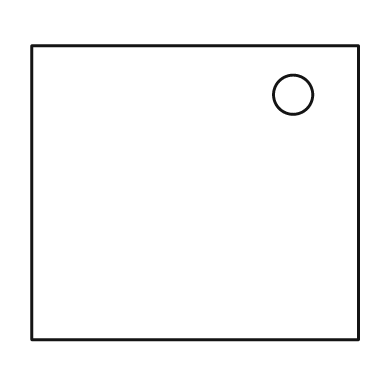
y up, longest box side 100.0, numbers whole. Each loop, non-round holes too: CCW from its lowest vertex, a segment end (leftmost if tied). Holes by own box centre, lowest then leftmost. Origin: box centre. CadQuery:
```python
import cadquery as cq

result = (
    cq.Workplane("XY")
    .moveTo(-50.0, -45.0)
    .lineTo(50.0, -45.0)
    .lineTo(50.0, 45.0)
    .lineTo(-50.0, 45.0)
    .close()
    .moveTo(30.0, 30.0)
    .circle(6.0)
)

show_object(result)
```